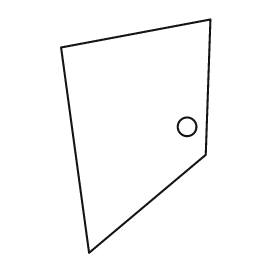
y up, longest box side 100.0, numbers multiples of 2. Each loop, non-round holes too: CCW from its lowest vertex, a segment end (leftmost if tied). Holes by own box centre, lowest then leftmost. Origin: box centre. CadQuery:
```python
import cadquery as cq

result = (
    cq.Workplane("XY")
    .moveTo(-20.0, -50.0)
    .lineTo(30.0, -8.0)
    .lineTo(32.0, 50.0)
    .lineTo(-32.0, 38.0)
    .close()
    .moveTo(22.0, 4.0)
    .circle(4.0)
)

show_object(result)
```